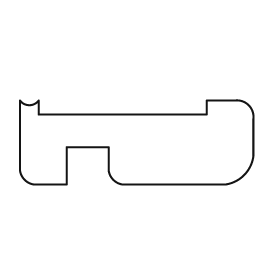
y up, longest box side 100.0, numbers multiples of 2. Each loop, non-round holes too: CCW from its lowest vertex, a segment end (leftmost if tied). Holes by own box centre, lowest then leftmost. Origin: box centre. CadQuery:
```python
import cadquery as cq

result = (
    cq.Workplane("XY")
    .moveTo(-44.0, -18.0)
    .lineTo(-30.0, -18.0)
    .lineTo(-30.0, -2.0)
    .lineTo(-12.0, -2.0)
    .lineTo(-12.0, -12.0)
    .threePointArc((-10.0, -16.0), (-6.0, -18.0))
    .lineTo(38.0, -18.0)
    .threePointArc((46.0, -14.0), (50.0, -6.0))
    .lineTo(50.0, 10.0)
    .threePointArc((48.0, 16.0), (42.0, 18.0))
    .lineTo(30.0, 18.0)
    .lineTo(30.0, 12.0)
    .lineTo(-42.0, 12.0)
    .lineTo(-42.0, 18.0)
    .threePointArc((-46.0, 16.0), (-50.0, 18.0))
    .lineTo(-50.0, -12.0)
    .threePointArc((-48.0, -16.0), (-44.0, -18.0))
    .close()
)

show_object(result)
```